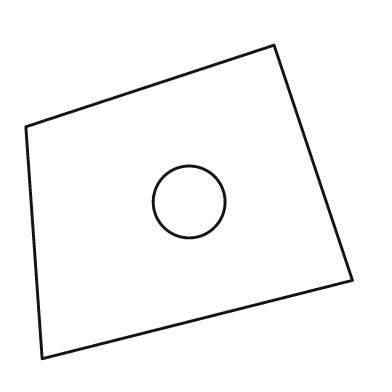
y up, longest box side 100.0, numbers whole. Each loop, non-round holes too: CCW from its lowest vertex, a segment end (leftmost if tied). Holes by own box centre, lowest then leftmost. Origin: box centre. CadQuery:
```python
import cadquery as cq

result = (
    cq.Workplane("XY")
    .moveTo(-45.0, -48.0)
    .lineTo(50.0, -24.0)
    .lineTo(26.0, 48.0)
    .lineTo(-50.0, 23.0)
    .close()
    .moveTo(0.0, 0.0)
    .circle(11.0)
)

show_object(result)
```